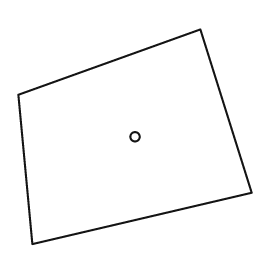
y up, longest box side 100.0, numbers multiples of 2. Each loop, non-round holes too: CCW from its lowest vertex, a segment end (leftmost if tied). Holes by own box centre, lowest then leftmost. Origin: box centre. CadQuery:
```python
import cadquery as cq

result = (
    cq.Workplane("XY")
    .moveTo(-44.0, -46.0)
    .lineTo(50.0, -24.0)
    .lineTo(28.0, 46.0)
    .lineTo(-50.0, 18.0)
    .close()
    .moveTo(0.0, 0.0)
    .circle(2.0)
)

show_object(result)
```